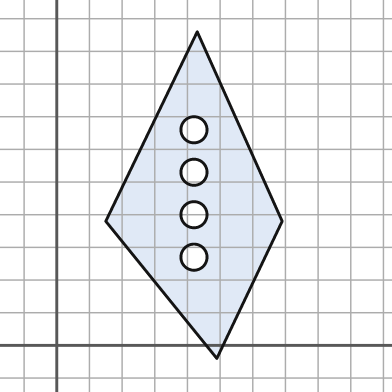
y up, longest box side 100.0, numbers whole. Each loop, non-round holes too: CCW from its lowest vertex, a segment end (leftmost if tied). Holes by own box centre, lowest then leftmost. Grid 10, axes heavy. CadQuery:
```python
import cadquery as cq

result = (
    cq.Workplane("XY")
    .moveTo(49.0, -4.0)
    .lineTo(69.0, 38.0)
    .lineTo(43.0, 96.0)
    .lineTo(15.0, 38.0)
    .close()
    .moveTo(42.0, 27.0)
    .circle(4.0)
    .moveTo(42.0, 40.0)
    .circle(4.0)
    .moveTo(42.0, 53.0)
    .circle(4.0)
    .moveTo(42.0, 66.0)
    .circle(4.0)
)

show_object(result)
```